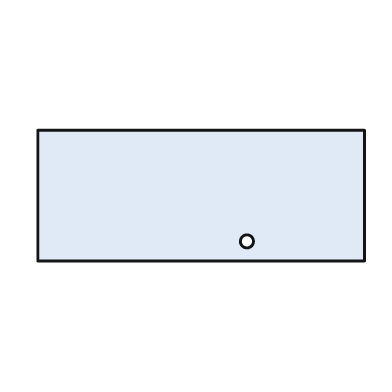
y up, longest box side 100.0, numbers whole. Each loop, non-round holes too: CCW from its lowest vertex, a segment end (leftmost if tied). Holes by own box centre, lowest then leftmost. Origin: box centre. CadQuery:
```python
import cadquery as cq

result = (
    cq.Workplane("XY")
    .moveTo(-50.0, -20.0)
    .lineTo(50.0, -20.0)
    .lineTo(50.0, 20.0)
    .lineTo(-50.0, 20.0)
    .close()
    .moveTo(14.0, -14.0)
    .circle(2.0)
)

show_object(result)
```